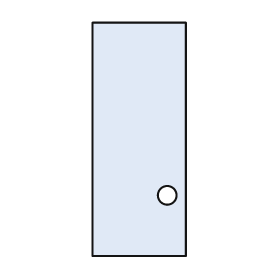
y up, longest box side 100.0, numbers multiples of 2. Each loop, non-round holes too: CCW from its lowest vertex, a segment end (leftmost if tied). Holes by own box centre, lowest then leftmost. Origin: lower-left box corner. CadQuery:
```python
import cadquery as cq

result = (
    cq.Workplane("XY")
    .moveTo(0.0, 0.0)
    .lineTo(40.0, 0.0)
    .lineTo(40.0, 100.0)
    .lineTo(0.0, 100.0)
    .close()
    .moveTo(32.0, 26.0)
    .circle(4.0)
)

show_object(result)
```